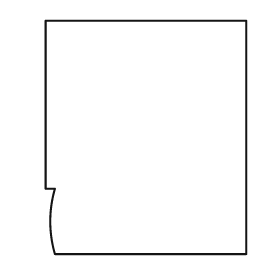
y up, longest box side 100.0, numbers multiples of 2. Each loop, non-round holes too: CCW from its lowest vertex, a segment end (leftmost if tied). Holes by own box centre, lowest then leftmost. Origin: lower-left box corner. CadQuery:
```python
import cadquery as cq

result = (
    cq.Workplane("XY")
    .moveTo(4.0, 0.0)
    .lineTo(86.0, 0.0)
    .lineTo(86.0, 100.0)
    .lineTo(0.0, 100.0)
    .lineTo(0.0, 28.0)
    .lineTo(4.0, 28.0)
    .threePointArc((2.0, 14.0), (4.0, 0.0))
    .close()
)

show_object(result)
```